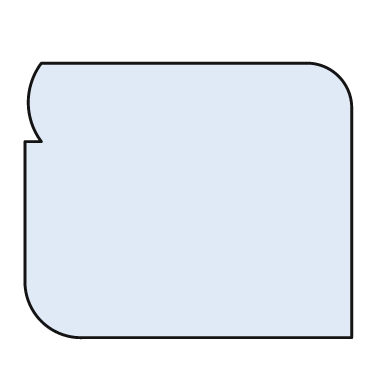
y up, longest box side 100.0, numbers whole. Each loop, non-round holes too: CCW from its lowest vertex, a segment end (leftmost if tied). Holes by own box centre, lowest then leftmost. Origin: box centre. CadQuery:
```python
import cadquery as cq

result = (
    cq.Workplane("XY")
    .moveTo(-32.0, -42.0)
    .lineTo(50.0, -42.0)
    .lineTo(50.0, 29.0)
    .threePointArc((46.0, 38.0), (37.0, 42.0))
    .lineTo(-45.0, 42.0)
    .threePointArc((-49.0, 30.0), (-45.0, 18.0))
    .lineTo(-50.0, 18.0)
    .lineTo(-50.0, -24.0)
    .threePointArc((-45.0, -37.0), (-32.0, -42.0))
    .close()
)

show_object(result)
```